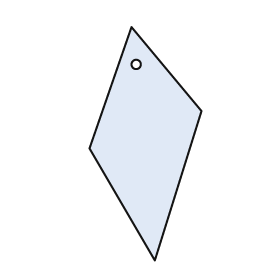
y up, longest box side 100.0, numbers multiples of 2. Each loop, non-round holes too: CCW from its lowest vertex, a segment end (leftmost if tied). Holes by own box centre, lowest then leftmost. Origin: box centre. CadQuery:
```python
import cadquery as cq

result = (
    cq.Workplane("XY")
    .moveTo(4.0, -50.0)
    .lineTo(24.0, 14.0)
    .lineTo(-6.0, 50.0)
    .lineTo(-24.0, -2.0)
    .close()
    .moveTo(-4.0, 34.0)
    .circle(2.0)
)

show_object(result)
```